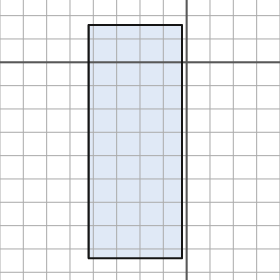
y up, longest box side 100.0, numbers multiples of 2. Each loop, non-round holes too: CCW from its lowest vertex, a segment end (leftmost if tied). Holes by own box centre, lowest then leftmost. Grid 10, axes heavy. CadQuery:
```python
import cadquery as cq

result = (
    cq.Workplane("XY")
    .moveTo(-42.0, -84.0)
    .lineTo(-2.0, -84.0)
    .lineTo(-2.0, 16.0)
    .lineTo(-42.0, 16.0)
    .close()
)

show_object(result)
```